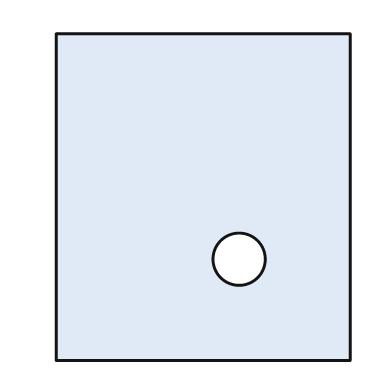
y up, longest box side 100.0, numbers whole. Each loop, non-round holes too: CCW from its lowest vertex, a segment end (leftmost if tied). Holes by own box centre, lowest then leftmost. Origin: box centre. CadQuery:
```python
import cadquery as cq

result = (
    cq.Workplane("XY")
    .moveTo(-45.0, -50.0)
    .lineTo(45.0, -50.0)
    .lineTo(45.0, 50.0)
    .lineTo(-45.0, 50.0)
    .close()
    .moveTo(11.0, -19.0)
    .circle(8.0)
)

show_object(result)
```